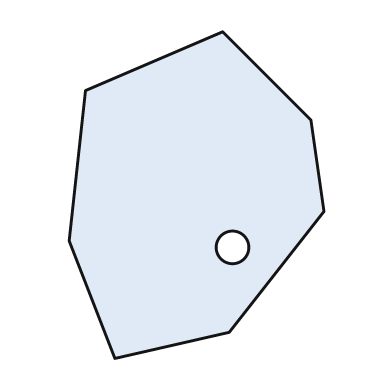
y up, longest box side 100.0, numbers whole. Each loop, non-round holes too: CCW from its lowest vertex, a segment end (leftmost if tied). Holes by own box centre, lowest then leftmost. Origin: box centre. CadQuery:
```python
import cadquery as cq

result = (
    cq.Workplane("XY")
    .moveTo(-25.0, -50.0)
    .lineTo(10.0, -42.0)
    .lineTo(39.0, -5.0)
    .lineTo(35.0, 23.0)
    .lineTo(8.0, 50.0)
    .lineTo(-34.0, 32.0)
    .lineTo(-39.0, -14.0)
    .close()
    .moveTo(11.0, -16.0)
    .circle(5.0)
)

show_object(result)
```